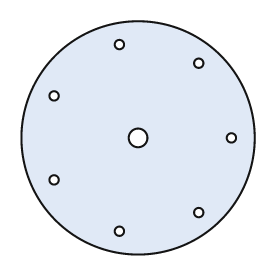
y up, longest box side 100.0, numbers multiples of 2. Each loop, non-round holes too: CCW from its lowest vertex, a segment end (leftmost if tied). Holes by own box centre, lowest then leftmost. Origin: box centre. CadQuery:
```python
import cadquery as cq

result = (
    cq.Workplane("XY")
    .moveTo(0.0, 0.0)
    .circle(50.0)
    .moveTo(-8.0, -40.0)
    .circle(2.0)
    .moveTo(26.0, -32.0)
    .circle(2.0)
    .moveTo(-36.0, -18.0)
    .circle(2.0)
    .moveTo(0.0, 0.0)
    .circle(4.0)
    .moveTo(40.0, 0.0)
    .circle(2.0)
    .moveTo(-36.0, 18.0)
    .circle(2.0)
    .moveTo(26.0, 32.0)
    .circle(2.0)
    .moveTo(-8.0, 40.0)
    .circle(2.0)
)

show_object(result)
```